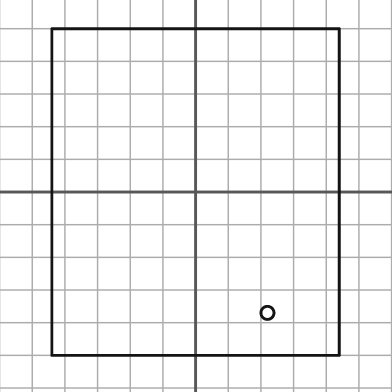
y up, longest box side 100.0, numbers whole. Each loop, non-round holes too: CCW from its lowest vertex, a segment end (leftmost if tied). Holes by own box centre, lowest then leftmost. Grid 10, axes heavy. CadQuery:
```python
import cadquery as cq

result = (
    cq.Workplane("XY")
    .moveTo(-44.0, -50.0)
    .lineTo(44.0, -50.0)
    .lineTo(44.0, 50.0)
    .lineTo(-44.0, 50.0)
    .close()
    .moveTo(22.0, -37.0)
    .circle(2.0)
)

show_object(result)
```